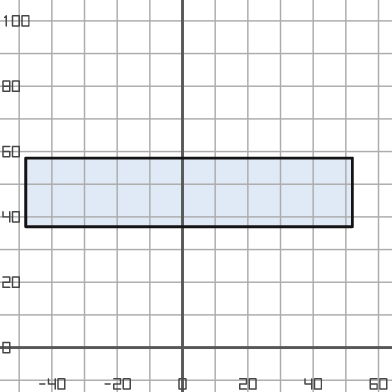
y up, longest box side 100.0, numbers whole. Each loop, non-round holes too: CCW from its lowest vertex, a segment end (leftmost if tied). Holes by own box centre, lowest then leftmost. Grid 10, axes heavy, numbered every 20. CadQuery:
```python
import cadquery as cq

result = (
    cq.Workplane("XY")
    .moveTo(-48.0, 37.0)
    .lineTo(52.0, 37.0)
    .lineTo(52.0, 58.0)
    .lineTo(-48.0, 58.0)
    .close()
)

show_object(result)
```